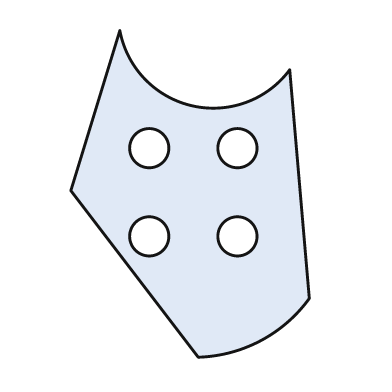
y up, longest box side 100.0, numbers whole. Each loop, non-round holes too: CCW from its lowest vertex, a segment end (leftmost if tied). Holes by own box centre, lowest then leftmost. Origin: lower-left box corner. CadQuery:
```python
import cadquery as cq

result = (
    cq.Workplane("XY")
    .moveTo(39.0, 0.0)
    .threePointArc((58.0, 5.0), (73.0, 18.0))
    .lineTo(67.0, 88.0)
    .threePointArc((37.0, 77.0), (15.0, 100.0))
    .lineTo(0.0, 51.0)
    .close()
    .moveTo(24.0, 37.0)
    .circle(6.0)
    .moveTo(51.0, 37.0)
    .circle(6.0)
    .moveTo(24.0, 64.0)
    .circle(6.0)
    .moveTo(51.0, 64.0)
    .circle(6.0)
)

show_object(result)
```